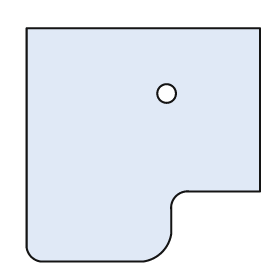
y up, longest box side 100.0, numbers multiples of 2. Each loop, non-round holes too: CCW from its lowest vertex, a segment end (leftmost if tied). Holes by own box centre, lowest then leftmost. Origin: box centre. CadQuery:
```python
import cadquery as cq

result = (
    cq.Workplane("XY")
    .moveTo(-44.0, -50.0)
    .lineTo(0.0, -50.0)
    .threePointArc((8.0, -46.0), (12.0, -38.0))
    .lineTo(12.0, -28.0)
    .threePointArc((14.0, -22.0), (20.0, -20.0))
    .lineTo(50.0, -20.0)
    .lineTo(50.0, 50.0)
    .lineTo(-50.0, 50.0)
    .lineTo(-50.0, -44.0)
    .threePointArc((-48.0, -48.0), (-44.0, -50.0))
    .close()
    .moveTo(10.0, 22.0)
    .circle(4.0)
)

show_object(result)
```